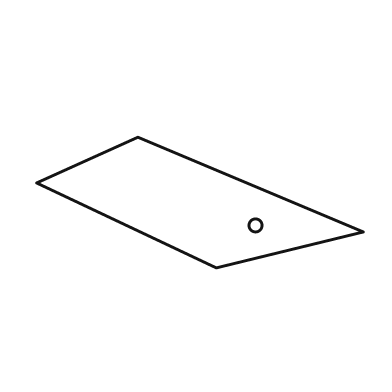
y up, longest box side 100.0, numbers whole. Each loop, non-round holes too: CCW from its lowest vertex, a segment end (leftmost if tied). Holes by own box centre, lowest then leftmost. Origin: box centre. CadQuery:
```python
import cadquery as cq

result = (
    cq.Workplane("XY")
    .moveTo(5.0, -20.0)
    .lineTo(50.0, -9.0)
    .lineTo(-19.0, 20.0)
    .lineTo(-50.0, 6.0)
    .close()
    .moveTo(17.0, -7.0)
    .circle(2.0)
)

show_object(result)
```